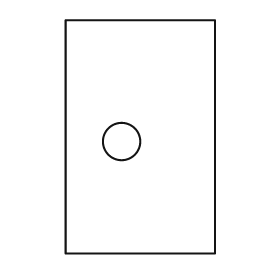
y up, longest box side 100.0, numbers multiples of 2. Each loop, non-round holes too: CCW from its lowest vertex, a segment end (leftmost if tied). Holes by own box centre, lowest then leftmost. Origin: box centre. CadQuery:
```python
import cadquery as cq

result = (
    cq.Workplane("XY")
    .moveTo(-32.0, -50.0)
    .lineTo(32.0, -50.0)
    .lineTo(32.0, 50.0)
    .lineTo(-32.0, 50.0)
    .close()
    .moveTo(-8.0, -2.0)
    .circle(8.0)
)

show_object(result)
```